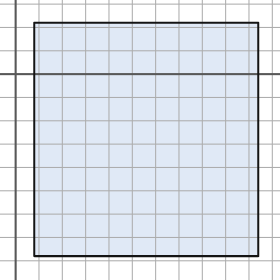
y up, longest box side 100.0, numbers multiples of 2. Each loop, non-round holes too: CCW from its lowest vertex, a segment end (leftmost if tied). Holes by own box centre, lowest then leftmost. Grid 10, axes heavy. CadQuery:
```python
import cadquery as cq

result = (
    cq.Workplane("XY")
    .moveTo(8.0, -78.0)
    .lineTo(104.0, -78.0)
    .lineTo(104.0, 22.0)
    .lineTo(8.0, 22.0)
    .close()
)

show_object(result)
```